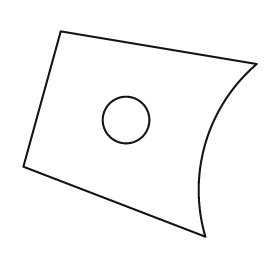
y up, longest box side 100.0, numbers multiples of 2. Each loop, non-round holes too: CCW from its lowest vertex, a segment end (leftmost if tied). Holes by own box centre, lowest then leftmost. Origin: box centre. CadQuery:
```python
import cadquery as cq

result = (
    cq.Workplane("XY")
    .moveTo(28.0, -44.0)
    .threePointArc((28.0, -4.0), (50.0, 30.0))
    .lineTo(-34.0, 44.0)
    .lineTo(-50.0, -14.0)
    .close()
    .moveTo(-6.0, 6.0)
    .circle(10.0)
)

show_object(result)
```